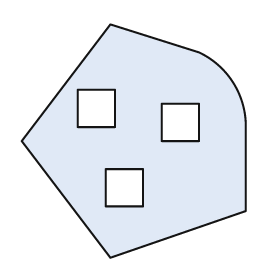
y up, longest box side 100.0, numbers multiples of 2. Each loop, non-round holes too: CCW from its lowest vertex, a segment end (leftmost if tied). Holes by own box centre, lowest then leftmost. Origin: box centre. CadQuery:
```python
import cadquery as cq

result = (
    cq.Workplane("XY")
    .moveTo(-10.0, -50.0)
    .lineTo(48.0, -30.0)
    .lineTo(48.0, 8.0)
    .threePointArc((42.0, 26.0), (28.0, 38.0))
    .lineTo(-10.0, 50.0)
    .lineTo(-48.0, 0.0)
    .close()
    .moveTo(-12.0, -28.0)
    .lineTo(4.0, -28.0)
    .lineTo(4.0, -12.0)
    .lineTo(-12.0, -12.0)
    .close()
    .moveTo(12.0, 0.0)
    .lineTo(28.0, 0.0)
    .lineTo(28.0, 16.0)
    .lineTo(12.0, 16.0)
    .close()
    .moveTo(-24.0, 6.0)
    .lineTo(-8.0, 6.0)
    .lineTo(-8.0, 22.0)
    .lineTo(-24.0, 22.0)
    .close()
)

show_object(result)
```